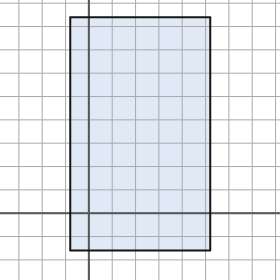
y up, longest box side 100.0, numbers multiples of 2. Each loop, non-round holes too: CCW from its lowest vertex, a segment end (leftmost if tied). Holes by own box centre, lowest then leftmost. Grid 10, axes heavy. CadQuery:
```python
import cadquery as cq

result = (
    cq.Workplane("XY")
    .moveTo(-8.0, -16.0)
    .lineTo(52.0, -16.0)
    .lineTo(52.0, 84.0)
    .lineTo(-8.0, 84.0)
    .close()
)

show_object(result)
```